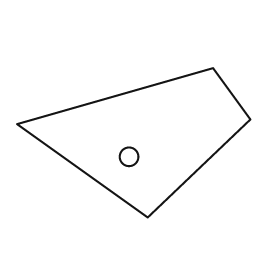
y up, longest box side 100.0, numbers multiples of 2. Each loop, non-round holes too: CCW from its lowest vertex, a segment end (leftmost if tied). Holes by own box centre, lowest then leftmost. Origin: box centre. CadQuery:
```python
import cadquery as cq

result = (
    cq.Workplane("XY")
    .moveTo(6.0, -32.0)
    .lineTo(50.0, 10.0)
    .lineTo(34.0, 32.0)
    .lineTo(-50.0, 8.0)
    .close()
    .moveTo(-2.0, -6.0)
    .circle(4.0)
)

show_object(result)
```